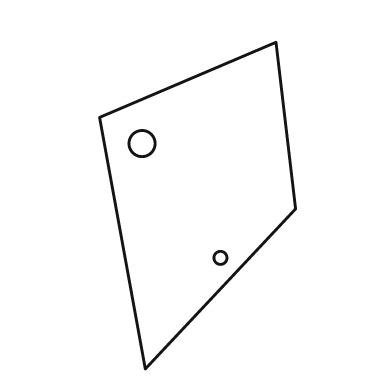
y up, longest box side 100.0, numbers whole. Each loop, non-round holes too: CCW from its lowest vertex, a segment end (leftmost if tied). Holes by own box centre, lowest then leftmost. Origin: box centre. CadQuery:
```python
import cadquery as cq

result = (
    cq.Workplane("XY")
    .moveTo(-16.0, -50.0)
    .lineTo(30.0, -1.0)
    .lineTo(24.0, 50.0)
    .lineTo(-30.0, 27.0)
    .close()
    .moveTo(7.0, -16.0)
    .circle(2.0)
    .moveTo(-17.0, 19.0)
    .circle(4.0)
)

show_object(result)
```